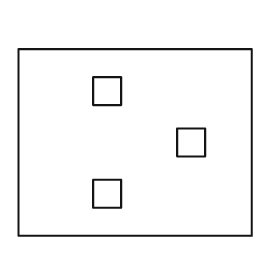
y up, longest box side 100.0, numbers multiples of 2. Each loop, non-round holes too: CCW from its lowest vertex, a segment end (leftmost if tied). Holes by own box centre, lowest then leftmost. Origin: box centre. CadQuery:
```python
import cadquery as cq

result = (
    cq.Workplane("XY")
    .moveTo(-50.0, -40.0)
    .lineTo(50.0, -40.0)
    .lineTo(50.0, 40.0)
    .lineTo(-50.0, 40.0)
    .close()
    .moveTo(-18.0, -28.0)
    .lineTo(-6.0, -28.0)
    .lineTo(-6.0, -16.0)
    .lineTo(-18.0, -16.0)
    .close()
    .moveTo(18.0, -6.0)
    .lineTo(30.0, -6.0)
    .lineTo(30.0, 6.0)
    .lineTo(18.0, 6.0)
    .close()
    .moveTo(-18.0, 16.0)
    .lineTo(-6.0, 16.0)
    .lineTo(-6.0, 28.0)
    .lineTo(-18.0, 28.0)
    .close()
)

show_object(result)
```